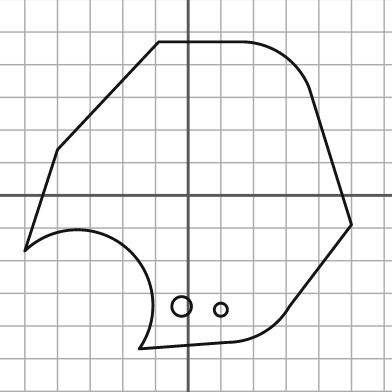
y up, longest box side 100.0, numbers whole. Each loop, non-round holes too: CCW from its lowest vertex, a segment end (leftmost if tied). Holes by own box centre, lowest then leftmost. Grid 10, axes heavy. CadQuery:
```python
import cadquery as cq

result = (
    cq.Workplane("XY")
    .moveTo(-15.0, -47.0)
    .lineTo(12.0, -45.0)
    .threePointArc((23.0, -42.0), (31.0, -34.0))
    .lineTo(50.0, -9.0)
    .lineTo(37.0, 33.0)
    .threePointArc((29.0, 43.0), (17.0, 47.0))
    .lineTo(-9.0, 47.0)
    .lineTo(-40.0, 14.0)
    .lineTo(-50.0, -17.0)
    .threePointArc((-19.0, -16.0), (-15.0, -47.0))
    .close()
    .moveTo(10.0, -35.0)
    .circle(2.0)
    .moveTo(-2.0, -34.0)
    .circle(3.0)
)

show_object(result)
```